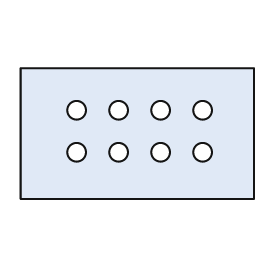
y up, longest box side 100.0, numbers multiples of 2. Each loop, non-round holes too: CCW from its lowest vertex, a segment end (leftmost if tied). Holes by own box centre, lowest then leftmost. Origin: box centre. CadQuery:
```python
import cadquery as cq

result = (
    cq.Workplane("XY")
    .moveTo(-50.0, -28.0)
    .lineTo(50.0, -28.0)
    .lineTo(50.0, 28.0)
    .lineTo(-50.0, 28.0)
    .close()
    .moveTo(-26.0, -8.0)
    .circle(4.0)
    .moveTo(-8.0, -8.0)
    .circle(4.0)
    .moveTo(10.0, -8.0)
    .circle(4.0)
    .moveTo(28.0, -8.0)
    .circle(4.0)
    .moveTo(-26.0, 10.0)
    .circle(4.0)
    .moveTo(-8.0, 10.0)
    .circle(4.0)
    .moveTo(10.0, 10.0)
    .circle(4.0)
    .moveTo(28.0, 10.0)
    .circle(4.0)
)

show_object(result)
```